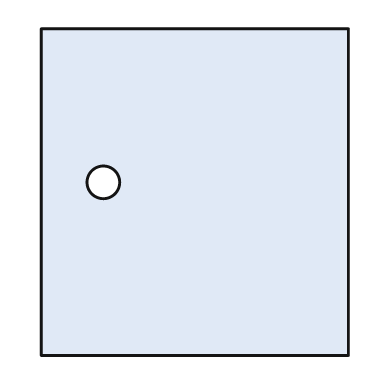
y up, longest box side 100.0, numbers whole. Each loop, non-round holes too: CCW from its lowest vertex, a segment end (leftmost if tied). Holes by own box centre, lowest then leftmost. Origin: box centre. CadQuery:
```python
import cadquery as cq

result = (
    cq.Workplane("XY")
    .moveTo(-47.0, -50.0)
    .lineTo(47.0, -50.0)
    .lineTo(47.0, 50.0)
    .lineTo(-47.0, 50.0)
    .close()
    .moveTo(-28.0, 3.0)
    .circle(5.0)
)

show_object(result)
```